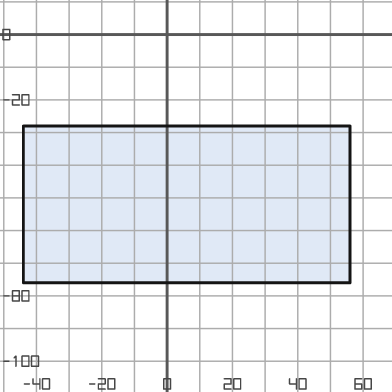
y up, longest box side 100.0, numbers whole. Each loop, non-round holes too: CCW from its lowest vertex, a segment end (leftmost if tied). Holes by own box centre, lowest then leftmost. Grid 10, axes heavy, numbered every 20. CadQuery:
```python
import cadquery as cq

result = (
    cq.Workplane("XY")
    .moveTo(-44.0, -76.0)
    .lineTo(56.0, -76.0)
    .lineTo(56.0, -28.0)
    .lineTo(-44.0, -28.0)
    .close()
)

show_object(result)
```